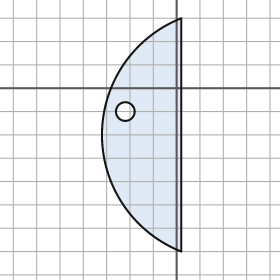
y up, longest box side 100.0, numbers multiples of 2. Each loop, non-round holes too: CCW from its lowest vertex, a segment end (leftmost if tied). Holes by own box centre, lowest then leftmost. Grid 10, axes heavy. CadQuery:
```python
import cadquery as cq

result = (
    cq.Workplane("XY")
    .moveTo(2.0, -70.0)
    .lineTo(2.0, 30.0)
    .threePointArc((-32.0, -20.0), (2.0, -70.0))
    .close()
    .moveTo(-22.0, -10.0)
    .circle(4.0)
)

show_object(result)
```